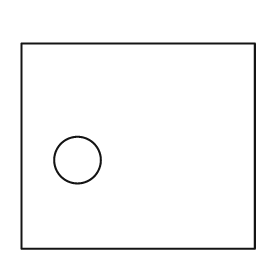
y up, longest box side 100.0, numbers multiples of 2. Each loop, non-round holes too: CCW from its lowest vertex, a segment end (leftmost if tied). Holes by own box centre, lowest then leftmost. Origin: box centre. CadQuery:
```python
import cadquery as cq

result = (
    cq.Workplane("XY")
    .moveTo(-50.0, -44.0)
    .lineTo(50.0, -44.0)
    .lineTo(50.0, 44.0)
    .lineTo(-50.0, 44.0)
    .close()
    .moveTo(-26.0, -6.0)
    .circle(10.0)
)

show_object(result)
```